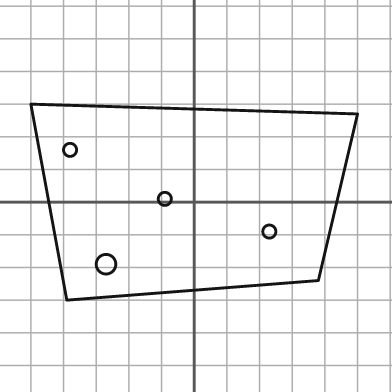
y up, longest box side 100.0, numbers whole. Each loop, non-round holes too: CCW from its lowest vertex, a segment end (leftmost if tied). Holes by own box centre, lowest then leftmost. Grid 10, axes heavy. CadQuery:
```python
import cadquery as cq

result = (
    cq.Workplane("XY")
    .moveTo(-39.0, -30.0)
    .lineTo(38.0, -24.0)
    .lineTo(50.0, 27.0)
    .lineTo(-50.0, 30.0)
    .close()
    .moveTo(-27.0, -19.0)
    .circle(3.0)
    .moveTo(23.0, -9.0)
    .circle(2.0)
    .moveTo(-9.0, 1.0)
    .circle(2.0)
    .moveTo(-38.0, 16.0)
    .circle(2.0)
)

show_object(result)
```